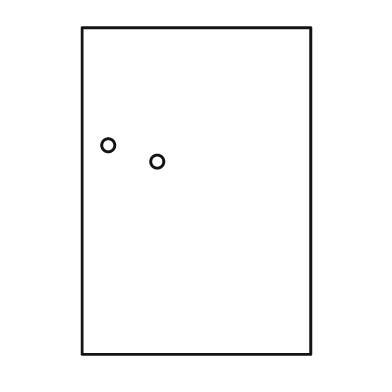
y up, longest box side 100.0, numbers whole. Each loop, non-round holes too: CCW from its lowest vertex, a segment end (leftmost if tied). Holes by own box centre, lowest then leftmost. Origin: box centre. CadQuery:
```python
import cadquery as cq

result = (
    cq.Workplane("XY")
    .moveTo(-35.0, -50.0)
    .lineTo(35.0, -50.0)
    .lineTo(35.0, 50.0)
    .lineTo(-35.0, 50.0)
    .close()
    .moveTo(-12.0, 9.0)
    .circle(2.0)
    .moveTo(-27.0, 14.0)
    .circle(2.0)
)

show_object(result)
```